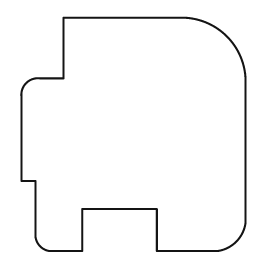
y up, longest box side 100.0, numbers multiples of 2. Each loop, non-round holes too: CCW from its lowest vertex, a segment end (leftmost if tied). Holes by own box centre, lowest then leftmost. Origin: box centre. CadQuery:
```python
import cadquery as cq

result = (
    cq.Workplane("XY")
    .moveTo(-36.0, -50.0)
    .lineTo(-22.0, -50.0)
    .lineTo(-22.0, -32.0)
    .lineTo(10.0, -32.0)
    .lineTo(10.0, -50.0)
    .lineTo(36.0, -50.0)
    .threePointArc((44.0, -46.0), (48.0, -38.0))
    .lineTo(48.0, 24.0)
    .threePointArc((40.0, 42.0), (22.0, 50.0))
    .lineTo(-30.0, 50.0)
    .lineTo(-30.0, 24.0)
    .lineTo(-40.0, 24.0)
    .threePointArc((-46.0, 22.0), (-48.0, 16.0))
    .lineTo(-48.0, -20.0)
    .lineTo(-42.0, -20.0)
    .lineTo(-42.0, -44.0)
    .threePointArc((-40.0, -48.0), (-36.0, -50.0))
    .close()
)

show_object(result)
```